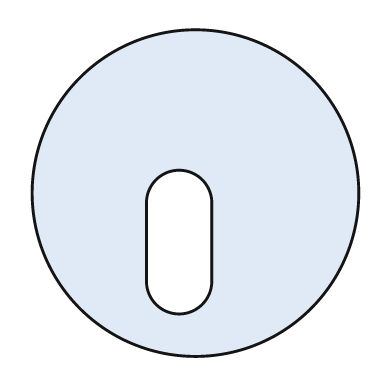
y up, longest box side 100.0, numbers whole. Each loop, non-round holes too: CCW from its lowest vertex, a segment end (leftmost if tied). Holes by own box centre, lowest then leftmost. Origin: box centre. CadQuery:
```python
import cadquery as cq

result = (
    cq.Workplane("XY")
    .moveTo(0.0, 0.0)
    .circle(50.0)
    .moveTo(-15.0, -27.0)
    .threePointArc((-5.0, -37.0), (5.0, -27.0))
    .lineTo(5.0, -3.0)
    .threePointArc((-5.0, 7.0), (-15.0, -3.0))
    .close()
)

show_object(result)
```